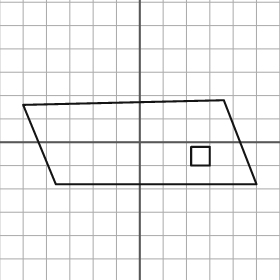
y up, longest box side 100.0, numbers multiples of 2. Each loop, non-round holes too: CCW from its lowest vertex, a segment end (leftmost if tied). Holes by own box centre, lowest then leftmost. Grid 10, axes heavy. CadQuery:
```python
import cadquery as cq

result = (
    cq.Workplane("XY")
    .moveTo(-36.0, -18.0)
    .lineTo(50.0, -18.0)
    .lineTo(36.0, 18.0)
    .lineTo(-50.0, 16.0)
    .close()
    .moveTo(22.0, -10.0)
    .lineTo(30.0, -10.0)
    .lineTo(30.0, -2.0)
    .lineTo(22.0, -2.0)
    .close()
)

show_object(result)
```